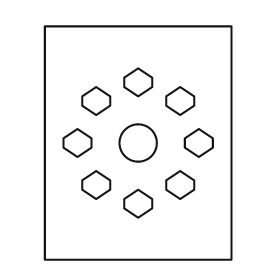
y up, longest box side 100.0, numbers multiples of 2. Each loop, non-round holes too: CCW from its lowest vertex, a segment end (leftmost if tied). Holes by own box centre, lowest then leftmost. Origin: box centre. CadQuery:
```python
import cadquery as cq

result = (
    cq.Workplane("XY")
    .moveTo(-40.0, -50.0)
    .lineTo(40.0, -50.0)
    .lineTo(40.0, 50.0)
    .lineTo(-40.0, 50.0)
    .close()
    .moveTo(0.0, -32.0)
    .lineTo(6.0, -28.0)
    .lineTo(6.0, -24.0)
    .lineTo(0.0, -20.0)
    .lineTo(-6.0, -24.0)
    .lineTo(-6.0, -28.0)
    .close()
    .moveTo(-18.0, -24.0)
    .lineTo(-12.0, -20.0)
    .lineTo(-12.0, -16.0)
    .lineTo(-18.0, -12.0)
    .lineTo(-24.0, -16.0)
    .lineTo(-24.0, -20.0)
    .close()
    .moveTo(18.0, -24.0)
    .lineTo(24.0, -20.0)
    .lineTo(24.0, -16.0)
    .lineTo(18.0, -12.0)
    .lineTo(12.0, -16.0)
    .lineTo(12.0, -20.0)
    .close()
    .moveTo(-26.0, -6.0)
    .lineTo(-20.0, -2.0)
    .lineTo(-20.0, 2.0)
    .lineTo(-26.0, 6.0)
    .lineTo(-32.0, 2.0)
    .lineTo(-32.0, -2.0)
    .close()
    .moveTo(0.0, 0.0)
    .circle(8.0)
    .moveTo(26.0, -6.0)
    .lineTo(32.0, -2.0)
    .lineTo(32.0, 2.0)
    .lineTo(26.0, 6.0)
    .lineTo(20.0, 2.0)
    .lineTo(20.0, -2.0)
    .close()
    .moveTo(-18.0, 12.0)
    .lineTo(-12.0, 16.0)
    .lineTo(-12.0, 20.0)
    .lineTo(-18.0, 24.0)
    .lineTo(-24.0, 20.0)
    .lineTo(-24.0, 16.0)
    .close()
    .moveTo(18.0, 12.0)
    .lineTo(24.0, 16.0)
    .lineTo(24.0, 20.0)
    .lineTo(18.0, 24.0)
    .lineTo(12.0, 20.0)
    .lineTo(12.0, 16.0)
    .close()
    .moveTo(0.0, 20.0)
    .lineTo(6.0, 24.0)
    .lineTo(6.0, 28.0)
    .lineTo(0.0, 32.0)
    .lineTo(-6.0, 28.0)
    .lineTo(-6.0, 24.0)
    .close()
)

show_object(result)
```